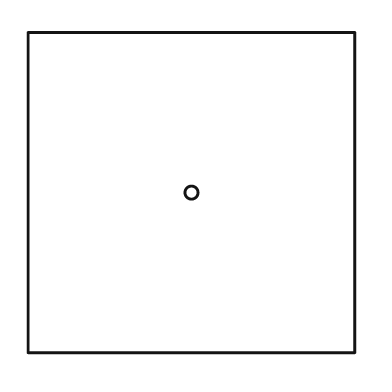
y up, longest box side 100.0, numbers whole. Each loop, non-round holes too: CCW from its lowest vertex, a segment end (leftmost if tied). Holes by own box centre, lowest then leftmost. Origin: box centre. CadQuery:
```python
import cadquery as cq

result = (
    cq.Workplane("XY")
    .moveTo(-50.0, -49.0)
    .lineTo(50.0, -49.0)
    .lineTo(50.0, 49.0)
    .lineTo(-50.0, 49.0)
    .close()
    .moveTo(0.0, 0.0)
    .circle(2.0)
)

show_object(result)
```